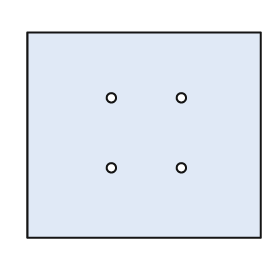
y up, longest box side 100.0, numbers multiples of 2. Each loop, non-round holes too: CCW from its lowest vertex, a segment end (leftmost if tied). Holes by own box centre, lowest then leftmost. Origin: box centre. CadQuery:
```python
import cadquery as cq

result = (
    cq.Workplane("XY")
    .moveTo(-50.0, -44.0)
    .lineTo(50.0, -44.0)
    .lineTo(50.0, 44.0)
    .lineTo(-50.0, 44.0)
    .close()
    .moveTo(-14.0, -14.0)
    .circle(2.0)
    .moveTo(16.0, -14.0)
    .circle(2.0)
    .moveTo(-14.0, 16.0)
    .circle(2.0)
    .moveTo(16.0, 16.0)
    .circle(2.0)
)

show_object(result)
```